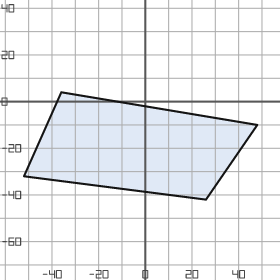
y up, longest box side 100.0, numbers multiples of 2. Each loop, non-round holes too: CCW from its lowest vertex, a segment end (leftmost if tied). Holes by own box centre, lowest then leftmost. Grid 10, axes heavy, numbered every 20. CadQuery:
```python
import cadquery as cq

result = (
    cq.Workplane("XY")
    .moveTo(26.0, -42.0)
    .lineTo(48.0, -10.0)
    .lineTo(-36.0, 4.0)
    .lineTo(-52.0, -32.0)
    .close()
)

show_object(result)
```